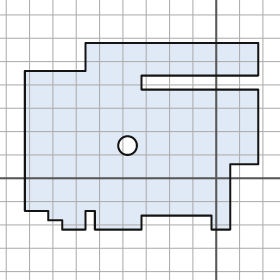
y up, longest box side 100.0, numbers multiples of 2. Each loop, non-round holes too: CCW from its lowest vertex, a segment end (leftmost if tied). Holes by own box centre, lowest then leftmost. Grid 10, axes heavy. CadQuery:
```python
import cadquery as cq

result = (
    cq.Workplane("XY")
    .moveTo(-66.0, -22.0)
    .lineTo(-56.0, -22.0)
    .lineTo(-56.0, -14.0)
    .lineTo(-52.0, -14.0)
    .lineTo(-52.0, -22.0)
    .lineTo(-32.0, -22.0)
    .lineTo(-32.0, -16.0)
    .lineTo(-2.0, -16.0)
    .lineTo(-2.0, -22.0)
    .lineTo(6.0, -22.0)
    .lineTo(6.0, 6.0)
    .lineTo(18.0, 6.0)
    .lineTo(18.0, 38.0)
    .lineTo(-32.0, 38.0)
    .lineTo(-32.0, 44.0)
    .lineTo(18.0, 44.0)
    .lineTo(18.0, 58.0)
    .lineTo(-56.0, 58.0)
    .lineTo(-56.0, 46.0)
    .lineTo(-82.0, 46.0)
    .lineTo(-82.0, -14.0)
    .lineTo(-72.0, -14.0)
    .lineTo(-72.0, -18.0)
    .lineTo(-66.0, -18.0)
    .close()
    .moveTo(-38.0, 14.0)
    .circle(4.0)
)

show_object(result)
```